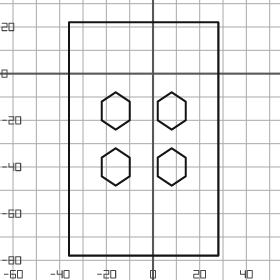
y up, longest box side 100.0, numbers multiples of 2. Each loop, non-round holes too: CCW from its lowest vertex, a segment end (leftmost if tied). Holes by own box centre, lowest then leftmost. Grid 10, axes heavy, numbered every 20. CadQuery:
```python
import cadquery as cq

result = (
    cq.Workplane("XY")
    .moveTo(-36.0, -78.0)
    .lineTo(28.0, -78.0)
    .lineTo(28.0, 22.0)
    .lineTo(-36.0, 22.0)
    .close()
    .moveTo(-16.0, -48.0)
    .lineTo(-10.0, -44.0)
    .lineTo(-10.0, -36.0)
    .lineTo(-16.0, -32.0)
    .lineTo(-22.0, -36.0)
    .lineTo(-22.0, -44.0)
    .close()
    .moveTo(8.0, -48.0)
    .lineTo(14.0, -44.0)
    .lineTo(14.0, -36.0)
    .lineTo(8.0, -32.0)
    .lineTo(2.0, -36.0)
    .lineTo(2.0, -44.0)
    .close()
    .moveTo(-16.0, -24.0)
    .lineTo(-10.0, -20.0)
    .lineTo(-10.0, -12.0)
    .lineTo(-16.0, -8.0)
    .lineTo(-22.0, -12.0)
    .lineTo(-22.0, -20.0)
    .close()
    .moveTo(8.0, -24.0)
    .lineTo(14.0, -20.0)
    .lineTo(14.0, -12.0)
    .lineTo(8.0, -8.0)
    .lineTo(2.0, -12.0)
    .lineTo(2.0, -20.0)
    .close()
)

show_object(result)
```